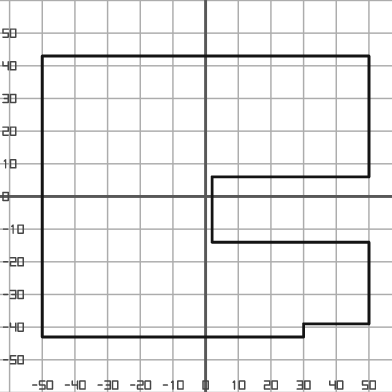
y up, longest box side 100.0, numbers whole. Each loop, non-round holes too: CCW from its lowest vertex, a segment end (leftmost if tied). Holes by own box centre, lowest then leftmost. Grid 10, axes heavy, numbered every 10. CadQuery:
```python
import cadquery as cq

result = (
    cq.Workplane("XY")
    .moveTo(-50.0, -43.0)
    .lineTo(30.0, -43.0)
    .lineTo(30.0, -39.0)
    .lineTo(50.0, -39.0)
    .lineTo(50.0, -14.0)
    .lineTo(2.0, -14.0)
    .lineTo(2.0, 6.0)
    .lineTo(50.0, 6.0)
    .lineTo(50.0, 43.0)
    .lineTo(-50.0, 43.0)
    .close()
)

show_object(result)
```